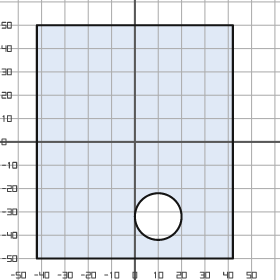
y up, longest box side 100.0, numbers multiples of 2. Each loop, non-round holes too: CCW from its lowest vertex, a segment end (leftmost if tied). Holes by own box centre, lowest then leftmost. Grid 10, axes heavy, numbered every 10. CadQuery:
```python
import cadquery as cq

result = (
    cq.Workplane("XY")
    .moveTo(-42.0, -50.0)
    .lineTo(42.0, -50.0)
    .lineTo(42.0, 50.0)
    .lineTo(-42.0, 50.0)
    .close()
    .moveTo(10.0, -32.0)
    .circle(10.0)
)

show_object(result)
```